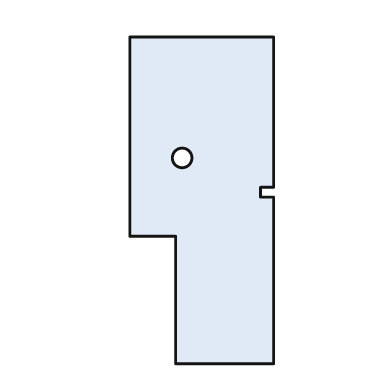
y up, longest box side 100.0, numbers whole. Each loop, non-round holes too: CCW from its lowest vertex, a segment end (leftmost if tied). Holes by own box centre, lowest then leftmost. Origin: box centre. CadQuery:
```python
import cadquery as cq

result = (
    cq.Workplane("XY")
    .moveTo(-8.0, -50.0)
    .lineTo(22.0, -50.0)
    .lineTo(22.0, 1.0)
    .lineTo(18.0, 1.0)
    .lineTo(18.0, 4.0)
    .lineTo(22.0, 4.0)
    .lineTo(22.0, 50.0)
    .lineTo(-22.0, 50.0)
    .lineTo(-22.0, -11.0)
    .lineTo(-8.0, -11.0)
    .close()
    .moveTo(-6.0, 13.0)
    .circle(3.0)
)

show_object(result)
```